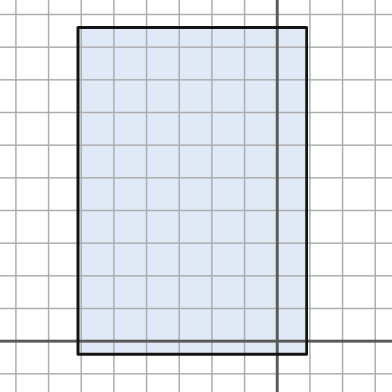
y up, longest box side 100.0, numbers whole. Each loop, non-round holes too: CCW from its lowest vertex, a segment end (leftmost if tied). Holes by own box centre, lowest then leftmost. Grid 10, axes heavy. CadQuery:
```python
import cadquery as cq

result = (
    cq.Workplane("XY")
    .moveTo(-61.0, -4.0)
    .lineTo(9.0, -4.0)
    .lineTo(9.0, 96.0)
    .lineTo(-61.0, 96.0)
    .close()
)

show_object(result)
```